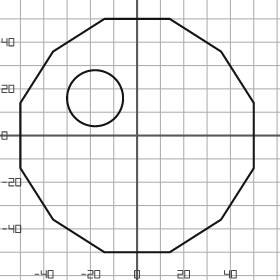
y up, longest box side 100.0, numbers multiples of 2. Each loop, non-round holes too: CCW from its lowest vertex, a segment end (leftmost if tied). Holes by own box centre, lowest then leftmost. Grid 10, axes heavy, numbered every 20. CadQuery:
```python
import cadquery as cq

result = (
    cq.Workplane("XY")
    .moveTo(-14.0, -50.0)
    .lineTo(14.0, -50.0)
    .lineTo(36.0, -36.0)
    .lineTo(50.0, -14.0)
    .lineTo(50.0, 14.0)
    .lineTo(36.0, 36.0)
    .lineTo(14.0, 50.0)
    .lineTo(-14.0, 50.0)
    .lineTo(-36.0, 36.0)
    .lineTo(-50.0, 14.0)
    .lineTo(-50.0, -14.0)
    .lineTo(-36.0, -36.0)
    .close()
    .moveTo(-18.0, 16.0)
    .circle(12.0)
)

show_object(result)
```